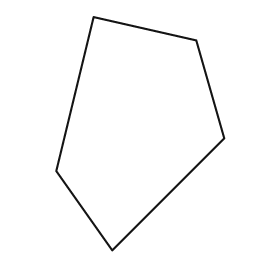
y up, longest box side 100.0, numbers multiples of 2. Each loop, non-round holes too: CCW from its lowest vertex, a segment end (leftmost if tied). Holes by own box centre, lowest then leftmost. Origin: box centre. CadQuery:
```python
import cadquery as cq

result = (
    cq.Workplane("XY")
    .moveTo(-12.0, -50.0)
    .lineTo(36.0, -2.0)
    .lineTo(24.0, 40.0)
    .lineTo(-20.0, 50.0)
    .lineTo(-36.0, -16.0)
    .close()
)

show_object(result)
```